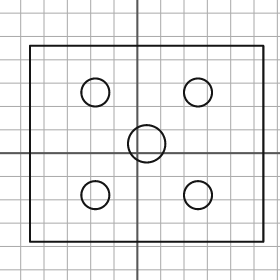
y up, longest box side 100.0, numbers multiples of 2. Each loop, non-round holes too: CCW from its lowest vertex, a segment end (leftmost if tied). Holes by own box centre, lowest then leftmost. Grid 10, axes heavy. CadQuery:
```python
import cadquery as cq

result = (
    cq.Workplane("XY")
    .moveTo(-46.0, -38.0)
    .lineTo(54.0, -38.0)
    .lineTo(54.0, 46.0)
    .lineTo(-46.0, 46.0)
    .close()
    .moveTo(-18.0, -18.0)
    .circle(6.0)
    .moveTo(26.0, -18.0)
    .circle(6.0)
    .moveTo(4.0, 4.0)
    .circle(8.0)
    .moveTo(-18.0, 26.0)
    .circle(6.0)
    .moveTo(26.0, 26.0)
    .circle(6.0)
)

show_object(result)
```